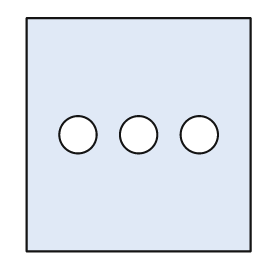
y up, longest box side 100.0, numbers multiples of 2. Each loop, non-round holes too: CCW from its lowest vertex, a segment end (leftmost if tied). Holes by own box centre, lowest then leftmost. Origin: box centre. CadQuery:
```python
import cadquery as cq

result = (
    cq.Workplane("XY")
    .moveTo(-48.0, -50.0)
    .lineTo(48.0, -50.0)
    .lineTo(48.0, 50.0)
    .lineTo(-48.0, 50.0)
    .close()
    .moveTo(-26.0, 0.0)
    .circle(8.0)
    .moveTo(0.0, 0.0)
    .circle(8.0)
    .moveTo(26.0, 0.0)
    .circle(8.0)
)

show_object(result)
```